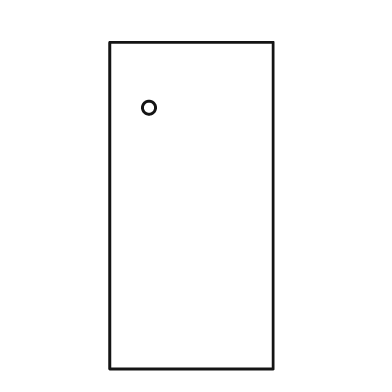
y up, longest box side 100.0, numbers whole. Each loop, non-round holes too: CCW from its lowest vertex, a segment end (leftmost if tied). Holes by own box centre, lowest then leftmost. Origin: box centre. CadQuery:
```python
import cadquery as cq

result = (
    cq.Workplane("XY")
    .moveTo(-25.0, -50.0)
    .lineTo(25.0, -50.0)
    .lineTo(25.0, 50.0)
    .lineTo(-25.0, 50.0)
    .close()
    .moveTo(-13.0, 30.0)
    .circle(2.0)
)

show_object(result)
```